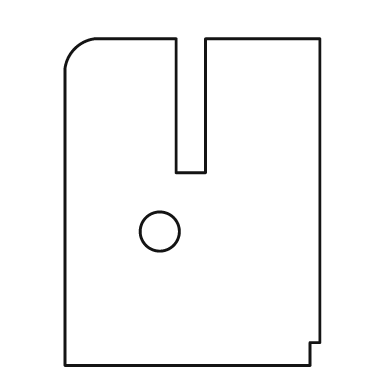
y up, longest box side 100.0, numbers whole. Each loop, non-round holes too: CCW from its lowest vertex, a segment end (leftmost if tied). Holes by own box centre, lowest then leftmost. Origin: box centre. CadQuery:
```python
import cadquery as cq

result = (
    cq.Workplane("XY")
    .moveTo(-39.0, -50.0)
    .lineTo(36.0, -50.0)
    .lineTo(36.0, -43.0)
    .lineTo(39.0, -43.0)
    .lineTo(39.0, 50.0)
    .lineTo(4.0, 50.0)
    .lineTo(4.0, 9.0)
    .lineTo(-5.0, 9.0)
    .lineTo(-5.0, 50.0)
    .lineTo(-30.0, 50.0)
    .threePointArc((-36.0, 47.0), (-39.0, 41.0))
    .close()
    .moveTo(-10.0, -9.0)
    .circle(6.0)
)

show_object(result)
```